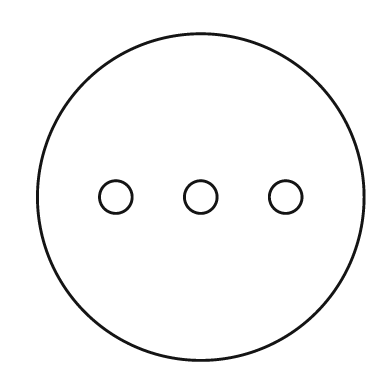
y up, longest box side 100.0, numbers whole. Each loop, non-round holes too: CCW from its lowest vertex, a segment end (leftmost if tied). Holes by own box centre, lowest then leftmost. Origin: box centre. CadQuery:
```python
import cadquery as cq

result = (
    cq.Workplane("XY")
    .moveTo(0.0, 0.0)
    .circle(50.0)
    .moveTo(-26.0, 0.0)
    .circle(5.0)
    .moveTo(0.0, 0.0)
    .circle(5.0)
    .moveTo(26.0, 0.0)
    .circle(5.0)
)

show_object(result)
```